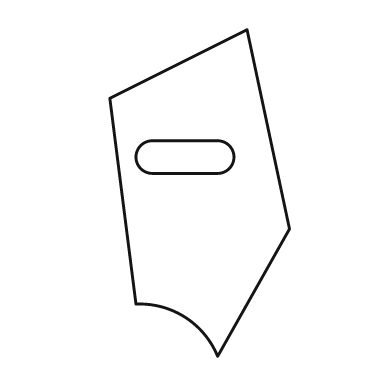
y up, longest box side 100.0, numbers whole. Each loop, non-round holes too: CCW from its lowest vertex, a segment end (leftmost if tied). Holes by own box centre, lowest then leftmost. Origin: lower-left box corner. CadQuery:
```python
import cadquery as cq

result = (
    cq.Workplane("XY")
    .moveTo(33.0, 0.0)
    .lineTo(55.0, 39.0)
    .lineTo(42.0, 100.0)
    .lineTo(0.0, 79.0)
    .lineTo(8.0, 16.0)
    .threePointArc((23.0, 12.0), (33.0, 0.0))
    .close()
    .moveTo(13.0, 56.0)
    .lineTo(33.0, 56.0)
    .threePointArc((38.0, 61.0), (33.0, 66.0))
    .lineTo(13.0, 66.0)
    .threePointArc((8.0, 61.0), (13.0, 56.0))
    .close()
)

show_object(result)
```